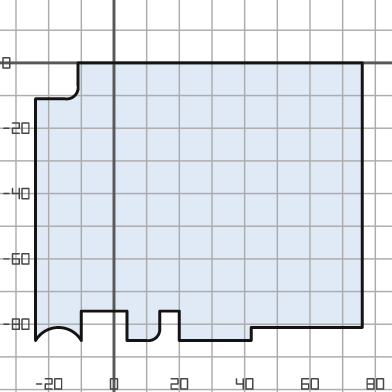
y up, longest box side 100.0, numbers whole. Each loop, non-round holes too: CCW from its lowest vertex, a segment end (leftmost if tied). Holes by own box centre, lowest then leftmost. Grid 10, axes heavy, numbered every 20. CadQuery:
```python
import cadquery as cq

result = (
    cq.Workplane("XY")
    .moveTo(-24.0, -85.0)
    .threePointArc((-17.0, -81.0), (-10.0, -85.0))
    .lineTo(-10.0, -76.0)
    .lineTo(4.0, -76.0)
    .lineTo(4.0, -85.0)
    .lineTo(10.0, -85.0)
    .threePointArc((13.0, -84.0), (14.0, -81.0))
    .lineTo(14.0, -76.0)
    .lineTo(20.0, -76.0)
    .lineTo(20.0, -85.0)
    .lineTo(42.0, -85.0)
    .lineTo(42.0, -81.0)
    .lineTo(76.0, -81.0)
    .lineTo(76.0, 0.0)
    .lineTo(-11.0, 0.0)
    .lineTo(-11.0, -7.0)
    .threePointArc((-12.0, -10.0), (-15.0, -11.0))
    .lineTo(-24.0, -11.0)
    .close()
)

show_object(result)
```